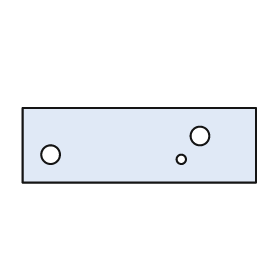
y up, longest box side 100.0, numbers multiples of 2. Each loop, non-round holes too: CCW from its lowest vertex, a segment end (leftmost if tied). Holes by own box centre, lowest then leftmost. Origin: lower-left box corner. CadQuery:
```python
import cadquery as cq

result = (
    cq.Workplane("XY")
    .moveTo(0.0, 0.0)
    .lineTo(100.0, 0.0)
    .lineTo(100.0, 32.0)
    .lineTo(0.0, 32.0)
    .close()
    .moveTo(68.0, 10.0)
    .circle(2.0)
    .moveTo(12.0, 12.0)
    .circle(4.0)
    .moveTo(76.0, 20.0)
    .circle(4.0)
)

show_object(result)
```